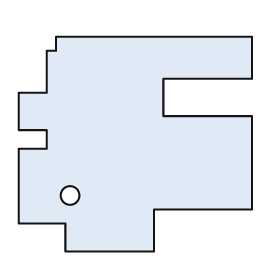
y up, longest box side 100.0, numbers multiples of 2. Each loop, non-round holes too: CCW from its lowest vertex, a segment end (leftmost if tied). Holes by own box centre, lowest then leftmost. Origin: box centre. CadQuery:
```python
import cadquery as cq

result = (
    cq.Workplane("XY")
    .moveTo(-30.0, -46.0)
    .lineTo(8.0, -46.0)
    .lineTo(8.0, -28.0)
    .lineTo(50.0, -28.0)
    .lineTo(50.0, 12.0)
    .lineTo(12.0, 12.0)
    .lineTo(12.0, 28.0)
    .lineTo(50.0, 28.0)
    .lineTo(50.0, 46.0)
    .lineTo(-34.0, 46.0)
    .lineTo(-34.0, 40.0)
    .lineTo(-38.0, 40.0)
    .lineTo(-38.0, 22.0)
    .lineTo(-50.0, 22.0)
    .lineTo(-50.0, 6.0)
    .lineTo(-38.0, 6.0)
    .lineTo(-38.0, -2.0)
    .lineTo(-50.0, -2.0)
    .lineTo(-50.0, -34.0)
    .lineTo(-30.0, -34.0)
    .close()
    .moveTo(-28.0, -22.0)
    .circle(4.0)
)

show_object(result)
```